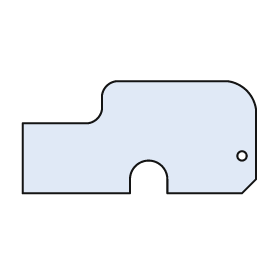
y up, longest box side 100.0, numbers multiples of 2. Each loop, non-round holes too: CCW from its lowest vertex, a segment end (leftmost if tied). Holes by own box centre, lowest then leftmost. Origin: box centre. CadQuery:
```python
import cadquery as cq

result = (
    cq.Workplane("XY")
    .moveTo(-50.0, -24.0)
    .lineTo(-4.0, -24.0)
    .lineTo(-4.0, -18.0)
    .threePointArc((4.0, -10.0), (12.0, -18.0))
    .lineTo(12.0, -24.0)
    .lineTo(44.0, -24.0)
    .lineTo(50.0, -18.0)
    .lineTo(50.0, 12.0)
    .threePointArc((46.0, 20.0), (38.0, 24.0))
    .lineTo(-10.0, 24.0)
    .threePointArc((-14.0, 22.0), (-16.0, 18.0))
    .lineTo(-16.0, 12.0)
    .threePointArc((-18.0, 8.0), (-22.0, 6.0))
    .lineTo(-50.0, 6.0)
    .close()
    .moveTo(44.0, -8.0)
    .circle(2.0)
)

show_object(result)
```